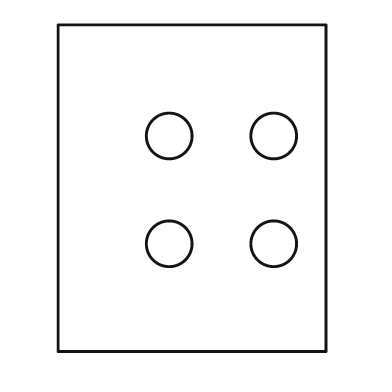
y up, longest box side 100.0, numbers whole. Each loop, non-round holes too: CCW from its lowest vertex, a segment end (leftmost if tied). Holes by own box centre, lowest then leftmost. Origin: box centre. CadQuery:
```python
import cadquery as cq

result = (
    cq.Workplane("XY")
    .moveTo(-41.0, -50.0)
    .lineTo(41.0, -50.0)
    .lineTo(41.0, 50.0)
    .lineTo(-41.0, 50.0)
    .close()
    .moveTo(-7.0, -17.0)
    .circle(7.0)
    .moveTo(25.0, -17.0)
    .circle(7.0)
    .moveTo(-7.0, 16.0)
    .circle(7.0)
    .moveTo(25.0, 16.0)
    .circle(7.0)
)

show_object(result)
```